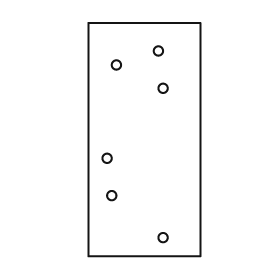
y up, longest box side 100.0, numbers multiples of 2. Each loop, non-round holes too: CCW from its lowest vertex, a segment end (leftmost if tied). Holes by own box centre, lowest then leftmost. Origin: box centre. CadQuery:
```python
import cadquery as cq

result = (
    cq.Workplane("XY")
    .moveTo(-24.0, -50.0)
    .lineTo(24.0, -50.0)
    .lineTo(24.0, 50.0)
    .lineTo(-24.0, 50.0)
    .close()
    .moveTo(8.0, -42.0)
    .circle(2.0)
    .moveTo(-14.0, -24.0)
    .circle(2.0)
    .moveTo(-16.0, -8.0)
    .circle(2.0)
    .moveTo(8.0, 22.0)
    .circle(2.0)
    .moveTo(-12.0, 32.0)
    .circle(2.0)
    .moveTo(6.0, 38.0)
    .circle(2.0)
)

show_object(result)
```